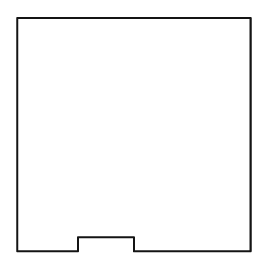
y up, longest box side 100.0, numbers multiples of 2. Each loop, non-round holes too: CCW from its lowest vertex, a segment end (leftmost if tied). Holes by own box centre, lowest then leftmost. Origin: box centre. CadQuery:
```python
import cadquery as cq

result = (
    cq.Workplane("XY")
    .moveTo(-50.0, -50.0)
    .lineTo(-24.0, -50.0)
    .lineTo(-24.0, -44.0)
    .lineTo(0.0, -44.0)
    .lineTo(0.0, -50.0)
    .lineTo(50.0, -50.0)
    .lineTo(50.0, 50.0)
    .lineTo(-50.0, 50.0)
    .close()
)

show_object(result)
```